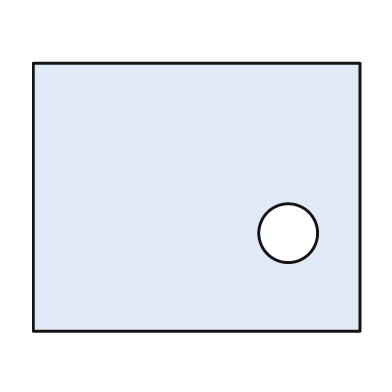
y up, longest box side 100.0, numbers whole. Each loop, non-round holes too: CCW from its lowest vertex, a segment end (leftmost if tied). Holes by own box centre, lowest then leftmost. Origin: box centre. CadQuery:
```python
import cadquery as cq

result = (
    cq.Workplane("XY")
    .moveTo(-50.0, -41.0)
    .lineTo(50.0, -41.0)
    .lineTo(50.0, 41.0)
    .lineTo(-50.0, 41.0)
    .close()
    .moveTo(28.0, -11.0)
    .circle(9.0)
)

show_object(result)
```